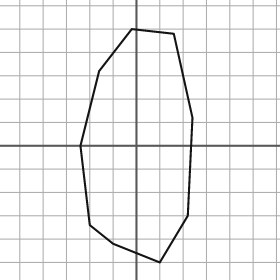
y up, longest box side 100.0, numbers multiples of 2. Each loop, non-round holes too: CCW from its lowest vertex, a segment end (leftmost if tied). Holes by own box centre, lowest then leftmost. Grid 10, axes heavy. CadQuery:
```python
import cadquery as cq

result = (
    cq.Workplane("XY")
    .moveTo(10.0, -50.0)
    .lineTo(22.0, -30.0)
    .lineTo(24.0, 12.0)
    .lineTo(16.0, 48.0)
    .lineTo(-2.0, 50.0)
    .lineTo(-16.0, 32.0)
    .lineTo(-24.0, 0.0)
    .lineTo(-20.0, -34.0)
    .lineTo(-10.0, -42.0)
    .close()
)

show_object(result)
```